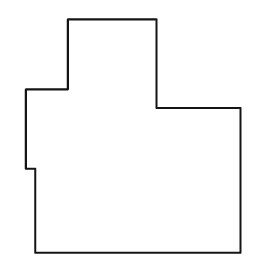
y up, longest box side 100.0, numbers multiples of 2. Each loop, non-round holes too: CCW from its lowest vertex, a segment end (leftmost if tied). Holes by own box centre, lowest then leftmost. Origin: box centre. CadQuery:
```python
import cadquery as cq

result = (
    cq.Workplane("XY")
    .moveTo(-42.0, -50.0)
    .lineTo(46.0, -50.0)
    .lineTo(46.0, 12.0)
    .lineTo(10.0, 12.0)
    .lineTo(10.0, 50.0)
    .lineTo(-28.0, 50.0)
    .lineTo(-28.0, 20.0)
    .lineTo(-46.0, 20.0)
    .lineTo(-46.0, -14.0)
    .lineTo(-42.0, -14.0)
    .close()
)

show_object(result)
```